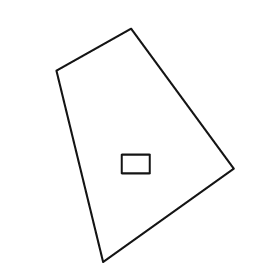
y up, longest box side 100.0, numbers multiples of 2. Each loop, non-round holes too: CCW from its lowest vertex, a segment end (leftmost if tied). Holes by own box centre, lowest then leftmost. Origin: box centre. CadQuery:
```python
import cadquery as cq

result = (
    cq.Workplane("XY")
    .moveTo(-18.0, -50.0)
    .lineTo(38.0, -10.0)
    .lineTo(-6.0, 50.0)
    .lineTo(-38.0, 32.0)
    .close()
    .moveTo(-10.0, -12.0)
    .lineTo(2.0, -12.0)
    .lineTo(2.0, -4.0)
    .lineTo(-10.0, -4.0)
    .close()
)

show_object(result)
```